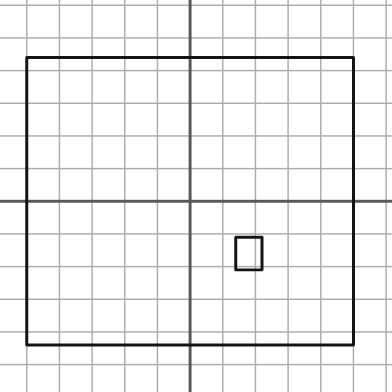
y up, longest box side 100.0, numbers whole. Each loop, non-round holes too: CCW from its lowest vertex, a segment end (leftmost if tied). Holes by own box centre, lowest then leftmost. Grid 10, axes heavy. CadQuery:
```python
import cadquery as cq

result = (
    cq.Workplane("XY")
    .moveTo(-50.0, -44.0)
    .lineTo(50.0, -44.0)
    .lineTo(50.0, 44.0)
    .lineTo(-50.0, 44.0)
    .close()
    .moveTo(14.0, -21.0)
    .lineTo(22.0, -21.0)
    .lineTo(22.0, -11.0)
    .lineTo(14.0, -11.0)
    .close()
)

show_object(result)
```